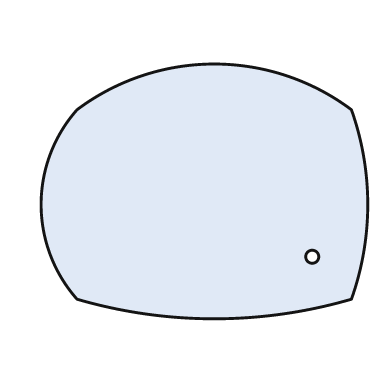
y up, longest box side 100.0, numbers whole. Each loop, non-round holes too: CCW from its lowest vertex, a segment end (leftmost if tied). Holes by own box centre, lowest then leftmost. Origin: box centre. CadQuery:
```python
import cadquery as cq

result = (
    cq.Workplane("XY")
    .moveTo(-39.0, -33.0)
    .threePointArc((3.0, -39.0), (45.0, -33.0))
    .threePointArc((50.0, -4.0), (45.0, 25.0))
    .threePointArc((3.0, 39.0), (-39.0, 25.0))
    .threePointArc((-50.0, -4.0), (-39.0, -33.0))
    .close()
    .moveTo(33.0, -20.0)
    .circle(2.0)
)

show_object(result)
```